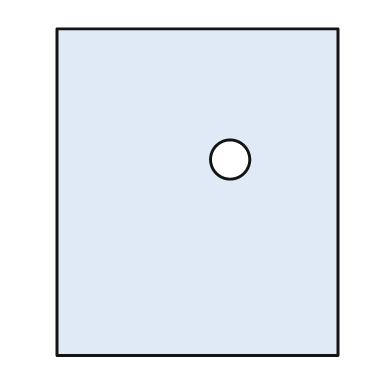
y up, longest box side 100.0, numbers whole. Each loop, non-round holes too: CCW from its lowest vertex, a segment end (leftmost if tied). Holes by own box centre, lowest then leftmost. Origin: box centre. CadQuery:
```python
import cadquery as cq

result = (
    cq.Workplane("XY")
    .moveTo(-43.0, -50.0)
    .lineTo(43.0, -50.0)
    .lineTo(43.0, 50.0)
    .lineTo(-43.0, 50.0)
    .close()
    .moveTo(10.0, 10.0)
    .circle(6.0)
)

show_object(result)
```